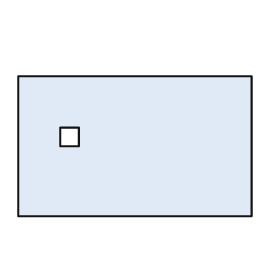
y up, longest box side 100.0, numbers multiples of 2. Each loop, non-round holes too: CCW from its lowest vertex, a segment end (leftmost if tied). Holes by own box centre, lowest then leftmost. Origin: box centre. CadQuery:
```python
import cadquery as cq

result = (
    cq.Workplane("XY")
    .moveTo(-50.0, -30.0)
    .lineTo(50.0, -30.0)
    .lineTo(50.0, 30.0)
    .lineTo(-50.0, 30.0)
    .close()
    .moveTo(-32.0, 0.0)
    .lineTo(-24.0, 0.0)
    .lineTo(-24.0, 8.0)
    .lineTo(-32.0, 8.0)
    .close()
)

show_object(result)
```